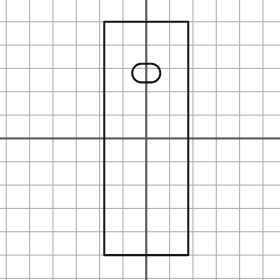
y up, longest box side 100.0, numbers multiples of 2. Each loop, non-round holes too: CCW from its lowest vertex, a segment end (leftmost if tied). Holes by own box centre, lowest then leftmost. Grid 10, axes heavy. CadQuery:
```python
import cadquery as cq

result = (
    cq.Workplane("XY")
    .moveTo(-18.0, -50.0)
    .lineTo(18.0, -50.0)
    .lineTo(18.0, 50.0)
    .lineTo(-18.0, 50.0)
    .close()
    .moveTo(-2.0, 24.0)
    .lineTo(2.0, 24.0)
    .threePointArc((6.0, 28.0), (2.0, 32.0))
    .lineTo(-2.0, 32.0)
    .threePointArc((-6.0, 28.0), (-2.0, 24.0))
    .close()
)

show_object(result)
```